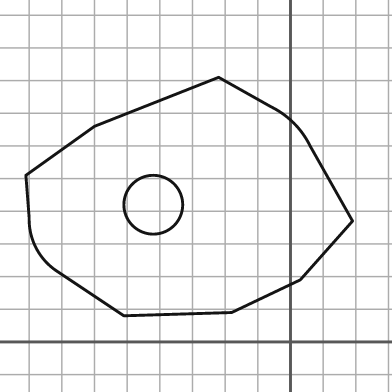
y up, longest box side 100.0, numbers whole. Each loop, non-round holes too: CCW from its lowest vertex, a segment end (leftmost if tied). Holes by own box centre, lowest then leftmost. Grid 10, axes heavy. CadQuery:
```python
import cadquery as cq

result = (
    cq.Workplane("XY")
    .moveTo(-51.0, 8.0)
    .lineTo(-18.0, 9.0)
    .lineTo(3.0, 19.0)
    .lineTo(19.0, 37.0)
    .lineTo(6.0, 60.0)
    .threePointArc((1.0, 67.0), (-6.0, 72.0))
    .lineTo(-22.0, 81.0)
    .lineTo(-60.0, 66.0)
    .lineTo(-81.0, 51.0)
    .lineTo(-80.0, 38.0)
    .threePointArc((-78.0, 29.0), (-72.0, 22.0))
    .close()
    .moveTo(-42.0, 42.0)
    .circle(9.0)
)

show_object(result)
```